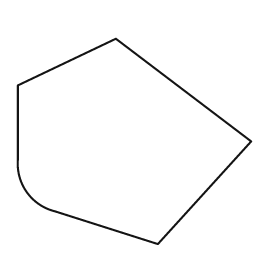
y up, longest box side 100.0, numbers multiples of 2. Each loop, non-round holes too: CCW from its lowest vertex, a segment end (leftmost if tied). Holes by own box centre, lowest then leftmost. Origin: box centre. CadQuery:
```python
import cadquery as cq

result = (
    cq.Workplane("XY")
    .moveTo(10.0, -44.0)
    .lineTo(50.0, 0.0)
    .lineTo(-8.0, 44.0)
    .lineTo(-50.0, 24.0)
    .lineTo(-50.0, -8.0)
    .threePointArc((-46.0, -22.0), (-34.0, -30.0))
    .close()
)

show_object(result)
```